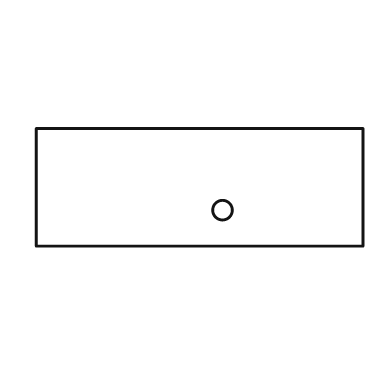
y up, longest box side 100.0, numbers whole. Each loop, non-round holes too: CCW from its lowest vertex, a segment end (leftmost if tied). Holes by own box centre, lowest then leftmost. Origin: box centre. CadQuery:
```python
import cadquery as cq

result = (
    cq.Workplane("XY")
    .moveTo(-50.0, -18.0)
    .lineTo(50.0, -18.0)
    .lineTo(50.0, 18.0)
    .lineTo(-50.0, 18.0)
    .close()
    .moveTo(7.0, -7.0)
    .circle(3.0)
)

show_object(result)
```